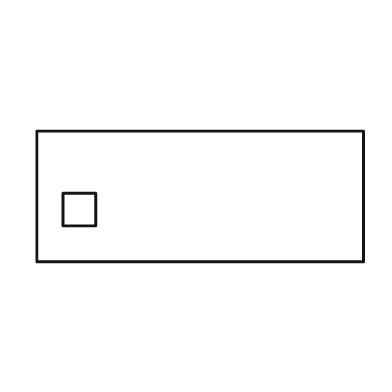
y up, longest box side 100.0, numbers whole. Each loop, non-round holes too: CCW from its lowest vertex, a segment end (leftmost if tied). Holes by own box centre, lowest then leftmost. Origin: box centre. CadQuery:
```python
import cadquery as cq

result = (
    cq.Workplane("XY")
    .moveTo(-50.0, -20.0)
    .lineTo(50.0, -20.0)
    .lineTo(50.0, 20.0)
    .lineTo(-50.0, 20.0)
    .close()
    .moveTo(-42.0, -9.0)
    .lineTo(-32.0, -9.0)
    .lineTo(-32.0, 1.0)
    .lineTo(-42.0, 1.0)
    .close()
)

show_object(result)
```